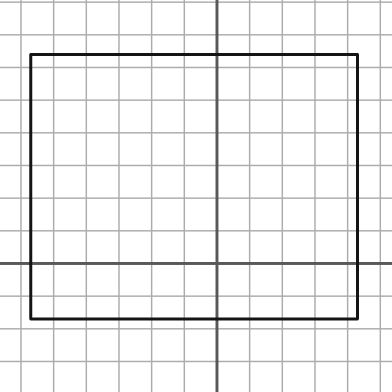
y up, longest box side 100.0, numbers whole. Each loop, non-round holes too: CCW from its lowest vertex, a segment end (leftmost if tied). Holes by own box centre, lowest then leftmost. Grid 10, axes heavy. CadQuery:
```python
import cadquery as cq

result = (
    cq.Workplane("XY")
    .moveTo(-57.0, -17.0)
    .lineTo(43.0, -17.0)
    .lineTo(43.0, 64.0)
    .lineTo(-57.0, 64.0)
    .close()
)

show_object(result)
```